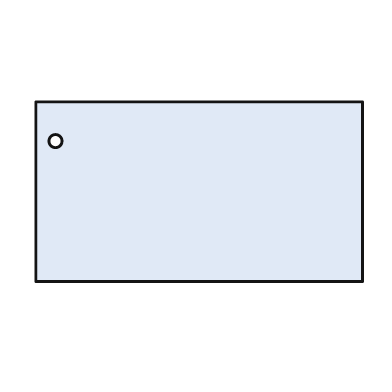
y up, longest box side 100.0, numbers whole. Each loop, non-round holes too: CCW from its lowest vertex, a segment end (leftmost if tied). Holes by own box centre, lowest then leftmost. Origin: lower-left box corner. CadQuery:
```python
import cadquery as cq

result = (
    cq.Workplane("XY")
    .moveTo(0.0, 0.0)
    .lineTo(100.0, 0.0)
    .lineTo(100.0, 55.0)
    .lineTo(0.0, 55.0)
    .close()
    .moveTo(6.0, 43.0)
    .circle(2.0)
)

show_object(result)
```